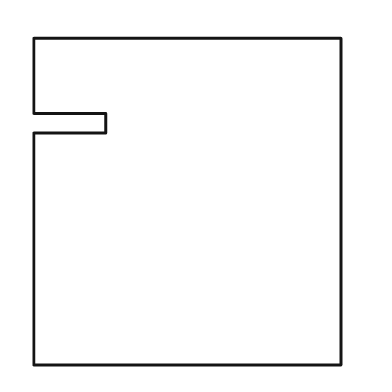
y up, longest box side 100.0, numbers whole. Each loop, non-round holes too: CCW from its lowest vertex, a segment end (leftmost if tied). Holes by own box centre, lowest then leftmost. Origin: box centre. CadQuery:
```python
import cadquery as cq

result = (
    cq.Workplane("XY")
    .moveTo(-47.0, -50.0)
    .lineTo(47.0, -50.0)
    .lineTo(47.0, 50.0)
    .lineTo(-47.0, 50.0)
    .lineTo(-47.0, 27.0)
    .lineTo(-25.0, 27.0)
    .lineTo(-25.0, 21.0)
    .lineTo(-47.0, 21.0)
    .close()
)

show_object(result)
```